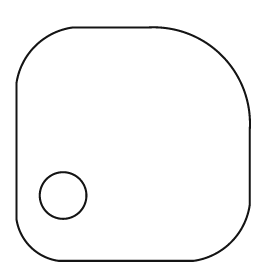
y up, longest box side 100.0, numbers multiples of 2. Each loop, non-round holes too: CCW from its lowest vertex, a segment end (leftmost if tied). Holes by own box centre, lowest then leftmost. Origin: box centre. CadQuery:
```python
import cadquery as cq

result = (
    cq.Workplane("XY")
    .moveTo(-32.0, -50.0)
    .lineTo(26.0, -50.0)
    .threePointArc((42.0, -42.0), (50.0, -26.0))
    .lineTo(50.0, 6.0)
    .threePointArc((38.0, 38.0), (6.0, 50.0))
    .lineTo(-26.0, 50.0)
    .threePointArc((-42.0, 42.0), (-50.0, 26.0))
    .lineTo(-50.0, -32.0)
    .threePointArc((-44.0, -44.0), (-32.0, -50.0))
    .close()
    .moveTo(-30.0, -22.0)
    .circle(10.0)
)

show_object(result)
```